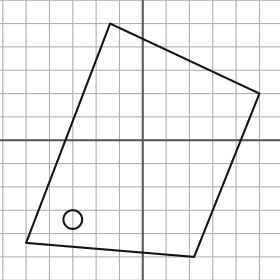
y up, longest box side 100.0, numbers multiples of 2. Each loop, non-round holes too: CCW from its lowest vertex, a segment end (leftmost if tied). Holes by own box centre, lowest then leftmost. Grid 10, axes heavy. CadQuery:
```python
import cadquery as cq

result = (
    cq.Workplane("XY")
    .moveTo(22.0, -50.0)
    .lineTo(50.0, 20.0)
    .lineTo(-14.0, 50.0)
    .lineTo(-50.0, -44.0)
    .close()
    .moveTo(-30.0, -34.0)
    .circle(4.0)
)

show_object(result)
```